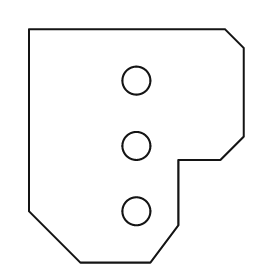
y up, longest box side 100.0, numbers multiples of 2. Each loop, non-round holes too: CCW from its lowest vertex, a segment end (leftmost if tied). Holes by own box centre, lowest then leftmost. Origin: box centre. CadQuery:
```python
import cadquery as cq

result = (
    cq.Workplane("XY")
    .moveTo(-24.0, -50.0)
    .lineTo(6.0, -50.0)
    .lineTo(18.0, -34.0)
    .lineTo(18.0, -6.0)
    .lineTo(36.0, -6.0)
    .lineTo(46.0, 4.0)
    .lineTo(46.0, 42.0)
    .lineTo(38.0, 50.0)
    .lineTo(-46.0, 50.0)
    .lineTo(-46.0, -28.0)
    .close()
    .moveTo(0.0, -28.0)
    .circle(6.0)
    .moveTo(0.0, 0.0)
    .circle(6.0)
    .moveTo(0.0, 28.0)
    .circle(6.0)
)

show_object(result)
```